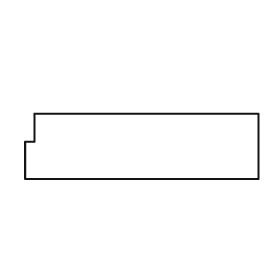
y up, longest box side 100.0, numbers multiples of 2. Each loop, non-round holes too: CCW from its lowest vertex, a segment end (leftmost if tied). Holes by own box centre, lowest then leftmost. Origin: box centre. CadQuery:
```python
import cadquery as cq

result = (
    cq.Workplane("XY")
    .moveTo(-50.0, -14.0)
    .lineTo(50.0, -14.0)
    .lineTo(50.0, 14.0)
    .lineTo(-46.0, 14.0)
    .lineTo(-46.0, 2.0)
    .lineTo(-50.0, 2.0)
    .close()
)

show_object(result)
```